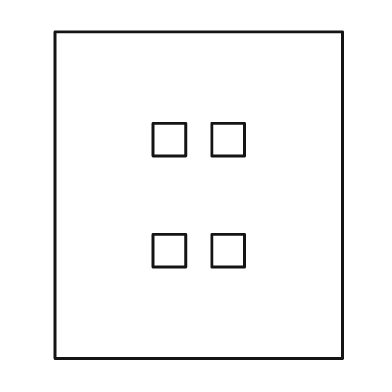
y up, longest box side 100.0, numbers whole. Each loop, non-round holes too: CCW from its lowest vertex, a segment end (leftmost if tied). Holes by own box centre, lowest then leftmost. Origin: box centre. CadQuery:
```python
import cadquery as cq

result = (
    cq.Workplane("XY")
    .moveTo(-44.0, -50.0)
    .lineTo(44.0, -50.0)
    .lineTo(44.0, 50.0)
    .lineTo(-44.0, 50.0)
    .close()
    .moveTo(-14.0, -22.0)
    .lineTo(-4.0, -22.0)
    .lineTo(-4.0, -12.0)
    .lineTo(-14.0, -12.0)
    .close()
    .moveTo(4.0, -22.0)
    .lineTo(14.0, -22.0)
    .lineTo(14.0, -12.0)
    .lineTo(4.0, -12.0)
    .close()
    .moveTo(-14.0, 12.0)
    .lineTo(-4.0, 12.0)
    .lineTo(-4.0, 22.0)
    .lineTo(-14.0, 22.0)
    .close()
    .moveTo(4.0, 12.0)
    .lineTo(14.0, 12.0)
    .lineTo(14.0, 22.0)
    .lineTo(4.0, 22.0)
    .close()
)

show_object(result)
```